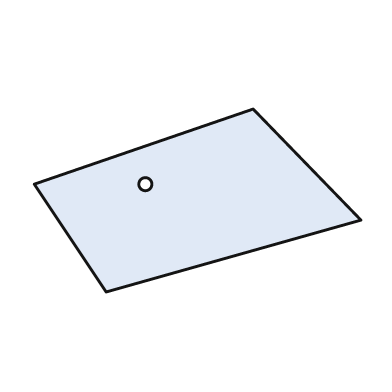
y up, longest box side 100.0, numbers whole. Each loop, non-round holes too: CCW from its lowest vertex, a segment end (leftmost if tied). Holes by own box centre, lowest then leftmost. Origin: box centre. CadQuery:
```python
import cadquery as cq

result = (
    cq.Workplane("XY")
    .moveTo(-28.0, -28.0)
    .lineTo(50.0, -6.0)
    .lineTo(17.0, 28.0)
    .lineTo(-50.0, 5.0)
    .close()
    .moveTo(-16.0, 5.0)
    .circle(2.0)
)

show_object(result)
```